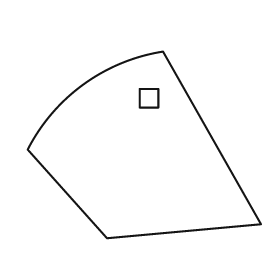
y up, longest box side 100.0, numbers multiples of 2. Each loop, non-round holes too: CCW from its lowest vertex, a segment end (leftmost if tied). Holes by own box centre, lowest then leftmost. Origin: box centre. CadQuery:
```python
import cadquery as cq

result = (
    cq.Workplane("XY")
    .moveTo(-16.0, -40.0)
    .lineTo(50.0, -34.0)
    .lineTo(8.0, 40.0)
    .threePointArc((-26.0, 26.0), (-50.0, -2.0))
    .close()
    .moveTo(-2.0, 16.0)
    .lineTo(6.0, 16.0)
    .lineTo(6.0, 24.0)
    .lineTo(-2.0, 24.0)
    .close()
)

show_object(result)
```